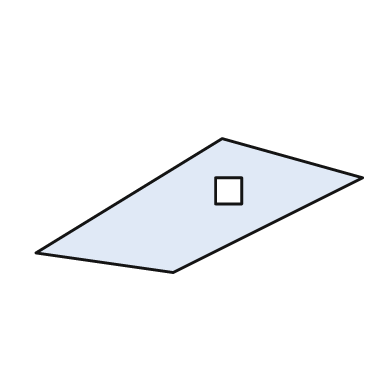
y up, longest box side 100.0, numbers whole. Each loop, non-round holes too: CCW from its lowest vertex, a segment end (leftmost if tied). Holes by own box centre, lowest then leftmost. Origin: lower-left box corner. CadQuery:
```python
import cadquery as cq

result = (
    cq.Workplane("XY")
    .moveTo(42.0, 0.0)
    .lineTo(100.0, 29.0)
    .lineTo(57.0, 41.0)
    .lineTo(0.0, 6.0)
    .close()
    .moveTo(55.0, 21.0)
    .lineTo(63.0, 21.0)
    .lineTo(63.0, 29.0)
    .lineTo(55.0, 29.0)
    .close()
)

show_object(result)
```